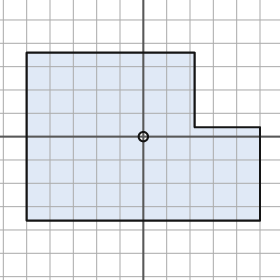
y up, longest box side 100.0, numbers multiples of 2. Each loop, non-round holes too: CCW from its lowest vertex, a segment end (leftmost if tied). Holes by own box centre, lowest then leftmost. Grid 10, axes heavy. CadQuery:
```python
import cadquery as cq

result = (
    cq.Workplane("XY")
    .moveTo(-50.0, -36.0)
    .lineTo(50.0, -36.0)
    .lineTo(50.0, 4.0)
    .lineTo(22.0, 4.0)
    .lineTo(22.0, 36.0)
    .lineTo(-50.0, 36.0)
    .close()
    .moveTo(0.0, 0.0)
    .circle(2.0)
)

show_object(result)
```